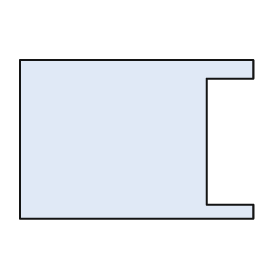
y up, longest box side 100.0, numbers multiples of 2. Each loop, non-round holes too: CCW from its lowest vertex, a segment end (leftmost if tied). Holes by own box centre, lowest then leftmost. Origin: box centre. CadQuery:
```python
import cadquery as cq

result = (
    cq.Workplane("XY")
    .moveTo(-50.0, -34.0)
    .lineTo(50.0, -34.0)
    .lineTo(50.0, -28.0)
    .lineTo(30.0, -28.0)
    .lineTo(30.0, 26.0)
    .lineTo(50.0, 26.0)
    .lineTo(50.0, 34.0)
    .lineTo(-50.0, 34.0)
    .close()
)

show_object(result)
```